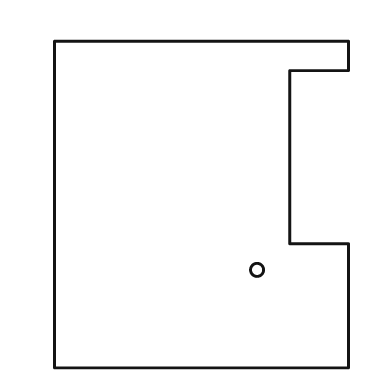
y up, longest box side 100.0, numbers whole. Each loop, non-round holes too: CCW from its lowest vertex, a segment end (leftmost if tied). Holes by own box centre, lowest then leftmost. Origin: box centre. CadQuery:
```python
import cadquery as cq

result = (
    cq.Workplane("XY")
    .moveTo(-45.0, -50.0)
    .lineTo(45.0, -50.0)
    .lineTo(45.0, -12.0)
    .lineTo(27.0, -12.0)
    .lineTo(27.0, 41.0)
    .lineTo(45.0, 41.0)
    .lineTo(45.0, 50.0)
    .lineTo(-45.0, 50.0)
    .close()
    .moveTo(17.0, -20.0)
    .circle(2.0)
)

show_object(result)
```